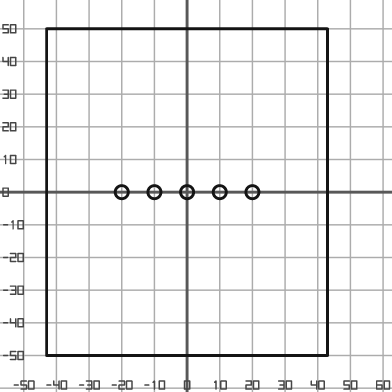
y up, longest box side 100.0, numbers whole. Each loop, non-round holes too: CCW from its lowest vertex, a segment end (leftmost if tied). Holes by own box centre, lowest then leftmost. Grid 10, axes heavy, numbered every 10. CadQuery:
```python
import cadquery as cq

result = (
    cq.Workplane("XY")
    .moveTo(-43.0, -50.0)
    .lineTo(43.0, -50.0)
    .lineTo(43.0, 50.0)
    .lineTo(-43.0, 50.0)
    .close()
    .moveTo(-20.0, 0.0)
    .circle(2.0)
    .moveTo(-10.0, 0.0)
    .circle(2.0)
    .moveTo(0.0, 0.0)
    .circle(2.0)
    .moveTo(10.0, 0.0)
    .circle(2.0)
    .moveTo(20.0, 0.0)
    .circle(2.0)
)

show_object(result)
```